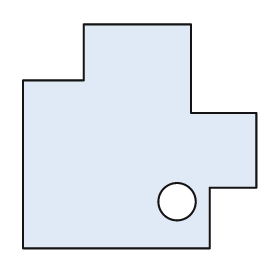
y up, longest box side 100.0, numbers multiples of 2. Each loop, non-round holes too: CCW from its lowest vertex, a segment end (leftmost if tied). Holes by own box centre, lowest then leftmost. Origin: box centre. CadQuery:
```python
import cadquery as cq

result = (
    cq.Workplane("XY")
    .moveTo(-50.0, -48.0)
    .lineTo(30.0, -48.0)
    .lineTo(30.0, -22.0)
    .lineTo(50.0, -22.0)
    .lineTo(50.0, 10.0)
    .lineTo(22.0, 10.0)
    .lineTo(22.0, 48.0)
    .lineTo(-24.0, 48.0)
    .lineTo(-24.0, 24.0)
    .lineTo(-50.0, 24.0)
    .close()
    .moveTo(16.0, -28.0)
    .circle(8.0)
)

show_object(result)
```